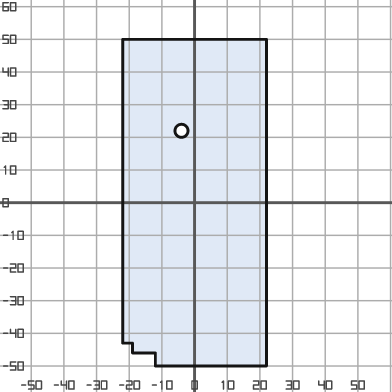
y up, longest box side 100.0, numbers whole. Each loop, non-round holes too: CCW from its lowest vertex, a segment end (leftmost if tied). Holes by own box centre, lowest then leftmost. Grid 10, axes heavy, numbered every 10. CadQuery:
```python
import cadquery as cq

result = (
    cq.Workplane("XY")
    .moveTo(-12.0, -50.0)
    .lineTo(22.0, -50.0)
    .lineTo(22.0, 50.0)
    .lineTo(-22.0, 50.0)
    .lineTo(-22.0, -43.0)
    .lineTo(-19.0, -43.0)
    .lineTo(-19.0, -46.0)
    .lineTo(-12.0, -46.0)
    .close()
    .moveTo(-4.0, 22.0)
    .circle(2.0)
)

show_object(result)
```